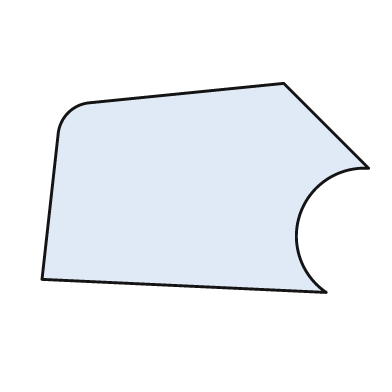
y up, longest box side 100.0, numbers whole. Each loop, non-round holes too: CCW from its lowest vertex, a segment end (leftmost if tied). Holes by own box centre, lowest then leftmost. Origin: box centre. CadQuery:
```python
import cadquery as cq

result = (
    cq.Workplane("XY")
    .moveTo(37.0, -32.0)
    .threePointArc((29.0, -8.0), (50.0, 6.0))
    .lineTo(24.0, 32.0)
    .lineTo(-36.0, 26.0)
    .threePointArc((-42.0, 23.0), (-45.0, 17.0))
    .lineTo(-50.0, -28.0)
    .close()
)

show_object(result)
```